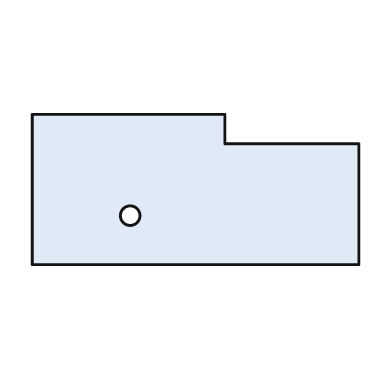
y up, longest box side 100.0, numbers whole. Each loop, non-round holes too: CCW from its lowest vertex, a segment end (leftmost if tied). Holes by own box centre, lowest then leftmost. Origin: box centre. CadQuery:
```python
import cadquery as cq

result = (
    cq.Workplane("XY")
    .moveTo(-50.0, -23.0)
    .lineTo(50.0, -23.0)
    .lineTo(50.0, 14.0)
    .lineTo(9.0, 14.0)
    .lineTo(9.0, 23.0)
    .lineTo(-50.0, 23.0)
    .close()
    .moveTo(-20.0, -8.0)
    .circle(3.0)
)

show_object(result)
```